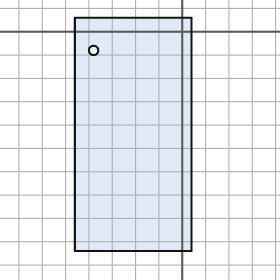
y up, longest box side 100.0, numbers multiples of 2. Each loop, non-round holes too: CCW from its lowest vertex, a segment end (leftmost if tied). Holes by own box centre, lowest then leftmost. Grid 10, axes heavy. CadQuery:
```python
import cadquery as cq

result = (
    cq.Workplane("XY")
    .moveTo(-46.0, -94.0)
    .lineTo(4.0, -94.0)
    .lineTo(4.0, 6.0)
    .lineTo(-46.0, 6.0)
    .close()
    .moveTo(-38.0, -8.0)
    .circle(2.0)
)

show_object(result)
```